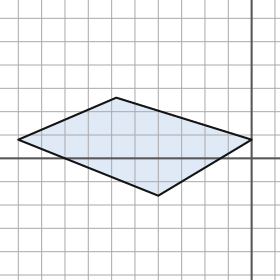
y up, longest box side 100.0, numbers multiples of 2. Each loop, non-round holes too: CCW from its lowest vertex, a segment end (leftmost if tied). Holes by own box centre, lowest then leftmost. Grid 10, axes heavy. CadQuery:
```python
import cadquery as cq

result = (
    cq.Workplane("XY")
    .moveTo(-40.0, -16.0)
    .lineTo(0.0, 8.0)
    .lineTo(-58.0, 26.0)
    .lineTo(-100.0, 8.0)
    .close()
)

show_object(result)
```